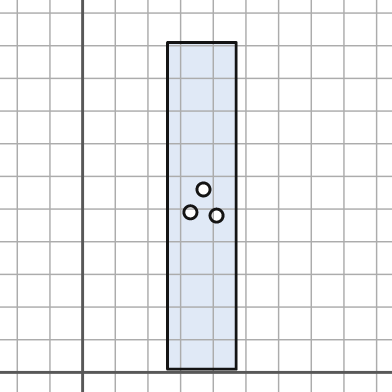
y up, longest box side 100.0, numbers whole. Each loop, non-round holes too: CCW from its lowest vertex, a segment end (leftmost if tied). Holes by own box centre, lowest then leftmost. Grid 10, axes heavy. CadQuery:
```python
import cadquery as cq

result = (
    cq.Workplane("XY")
    .moveTo(26.0, 1.0)
    .lineTo(47.0, 1.0)
    .lineTo(47.0, 101.0)
    .lineTo(26.0, 101.0)
    .close()
    .moveTo(41.0, 48.0)
    .circle(2.0)
    .moveTo(33.0, 49.0)
    .circle(2.0)
    .moveTo(37.0, 56.0)
    .circle(2.0)
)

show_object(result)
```